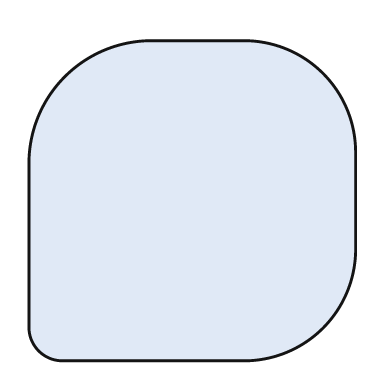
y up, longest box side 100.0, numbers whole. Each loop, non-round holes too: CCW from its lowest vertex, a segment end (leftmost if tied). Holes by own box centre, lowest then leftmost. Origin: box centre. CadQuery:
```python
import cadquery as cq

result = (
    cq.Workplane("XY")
    .moveTo(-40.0, -49.0)
    .lineTo(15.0, -49.0)
    .threePointArc((40.0, -39.0), (50.0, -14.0))
    .lineTo(50.0, 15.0)
    .threePointArc((40.0, 39.0), (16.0, 49.0))
    .lineTo(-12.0, 49.0)
    .threePointArc((-39.0, 38.0), (-50.0, 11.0))
    .lineTo(-50.0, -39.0)
    .threePointArc((-47.0, -46.0), (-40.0, -49.0))
    .close()
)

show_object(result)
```